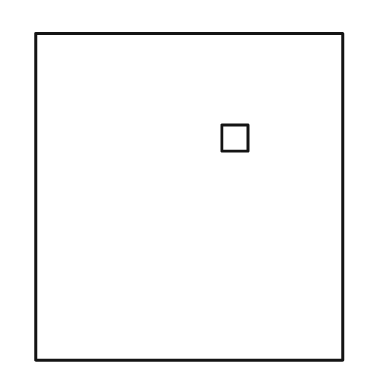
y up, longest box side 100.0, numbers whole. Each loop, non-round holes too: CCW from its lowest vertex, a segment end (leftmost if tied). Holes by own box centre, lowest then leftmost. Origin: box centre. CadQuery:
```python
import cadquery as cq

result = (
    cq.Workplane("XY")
    .moveTo(-47.0, -50.0)
    .lineTo(47.0, -50.0)
    .lineTo(47.0, 50.0)
    .lineTo(-47.0, 50.0)
    .close()
    .moveTo(10.0, 14.0)
    .lineTo(18.0, 14.0)
    .lineTo(18.0, 22.0)
    .lineTo(10.0, 22.0)
    .close()
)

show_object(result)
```